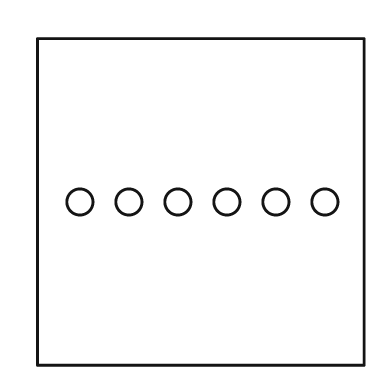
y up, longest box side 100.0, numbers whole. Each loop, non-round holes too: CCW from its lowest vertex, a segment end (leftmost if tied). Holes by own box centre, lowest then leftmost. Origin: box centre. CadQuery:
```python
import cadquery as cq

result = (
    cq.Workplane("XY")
    .moveTo(-50.0, -50.0)
    .lineTo(50.0, -50.0)
    .lineTo(50.0, 50.0)
    .lineTo(-50.0, 50.0)
    .close()
    .moveTo(-37.0, 0.0)
    .circle(4.0)
    .moveTo(-22.0, 0.0)
    .circle(4.0)
    .moveTo(-7.0, 0.0)
    .circle(4.0)
    .moveTo(8.0, 0.0)
    .circle(4.0)
    .moveTo(23.0, 0.0)
    .circle(4.0)
    .moveTo(38.0, 0.0)
    .circle(4.0)
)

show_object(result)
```